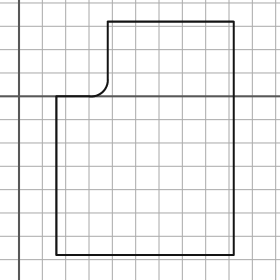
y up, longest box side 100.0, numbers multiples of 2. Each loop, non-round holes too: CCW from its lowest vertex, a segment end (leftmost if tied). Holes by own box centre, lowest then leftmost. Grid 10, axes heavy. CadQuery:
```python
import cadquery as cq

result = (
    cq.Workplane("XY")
    .moveTo(16.0, -68.0)
    .lineTo(92.0, -68.0)
    .lineTo(92.0, 32.0)
    .lineTo(38.0, 32.0)
    .lineTo(38.0, 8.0)
    .threePointArc((36.0, 2.0), (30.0, 0.0))
    .lineTo(16.0, 0.0)
    .close()
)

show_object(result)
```